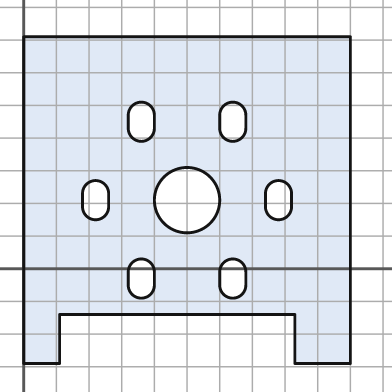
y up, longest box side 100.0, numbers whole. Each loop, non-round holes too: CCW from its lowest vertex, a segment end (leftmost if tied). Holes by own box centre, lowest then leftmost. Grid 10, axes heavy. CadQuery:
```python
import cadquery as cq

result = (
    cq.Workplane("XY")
    .moveTo(0.0, -29.0)
    .lineTo(11.0, -29.0)
    .lineTo(11.0, -14.0)
    .lineTo(83.0, -14.0)
    .lineTo(83.0, -29.0)
    .lineTo(100.0, -29.0)
    .lineTo(100.0, 71.0)
    .lineTo(0.0, 71.0)
    .close()
    .moveTo(32.0, -5.0)
    .threePointArc((36.0, -9.0), (40.0, -5.0))
    .lineTo(40.0, -1.0)
    .threePointArc((36.0, 3.0), (32.0, -1.0))
    .close()
    .moveTo(60.0, -5.0)
    .threePointArc((64.0, -9.0), (68.0, -5.0))
    .lineTo(68.0, -1.0)
    .threePointArc((64.0, 3.0), (60.0, -1.0))
    .close()
    .moveTo(18.0, 19.0)
    .threePointArc((22.0, 15.0), (26.0, 19.0))
    .lineTo(26.0, 23.0)
    .threePointArc((22.0, 27.0), (18.0, 23.0))
    .close()
    .moveTo(50.0, 21.0)
    .circle(10.0)
    .moveTo(74.0, 19.0)
    .threePointArc((78.0, 15.0), (82.0, 19.0))
    .lineTo(82.0, 23.0)
    .threePointArc((78.0, 27.0), (74.0, 23.0))
    .close()
    .moveTo(32.0, 43.0)
    .threePointArc((36.0, 39.0), (40.0, 43.0))
    .lineTo(40.0, 47.0)
    .threePointArc((36.0, 51.0), (32.0, 47.0))
    .close()
    .moveTo(60.0, 43.0)
    .threePointArc((64.0, 39.0), (68.0, 43.0))
    .lineTo(68.0, 47.0)
    .threePointArc((64.0, 51.0), (60.0, 47.0))
    .close()
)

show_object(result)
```